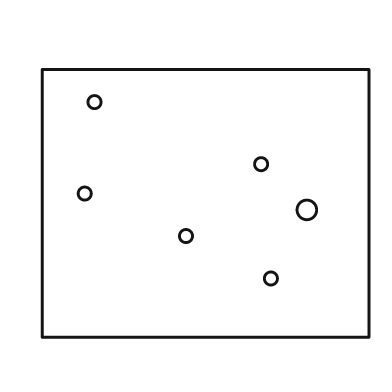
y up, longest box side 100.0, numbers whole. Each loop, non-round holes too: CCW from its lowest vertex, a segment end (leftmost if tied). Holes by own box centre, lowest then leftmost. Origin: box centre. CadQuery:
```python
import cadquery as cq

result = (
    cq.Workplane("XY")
    .moveTo(-50.0, -41.0)
    .lineTo(50.0, -41.0)
    .lineTo(50.0, 41.0)
    .lineTo(-50.0, 41.0)
    .close()
    .moveTo(20.0, -23.0)
    .circle(2.0)
    .moveTo(-6.0, -10.0)
    .circle(2.0)
    .moveTo(31.0, -2.0)
    .circle(3.0)
    .moveTo(-37.0, 3.0)
    .circle(2.0)
    .moveTo(17.0, 12.0)
    .circle(2.0)
    .moveTo(-34.0, 31.0)
    .circle(2.0)
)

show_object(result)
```